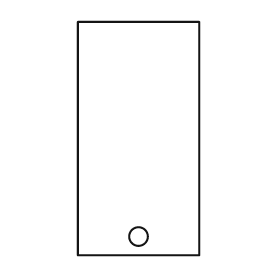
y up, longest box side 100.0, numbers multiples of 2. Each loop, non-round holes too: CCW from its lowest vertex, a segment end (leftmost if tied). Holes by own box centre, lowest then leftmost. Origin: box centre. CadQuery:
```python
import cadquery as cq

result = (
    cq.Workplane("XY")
    .moveTo(-26.0, -50.0)
    .lineTo(26.0, -50.0)
    .lineTo(26.0, 50.0)
    .lineTo(-26.0, 50.0)
    .close()
    .moveTo(0.0, -42.0)
    .circle(4.0)
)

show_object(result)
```